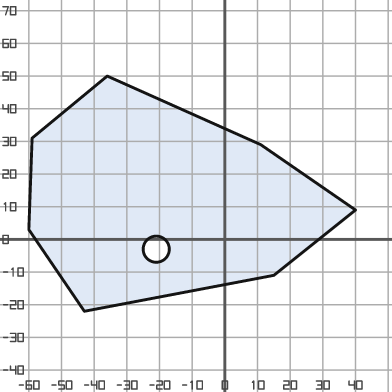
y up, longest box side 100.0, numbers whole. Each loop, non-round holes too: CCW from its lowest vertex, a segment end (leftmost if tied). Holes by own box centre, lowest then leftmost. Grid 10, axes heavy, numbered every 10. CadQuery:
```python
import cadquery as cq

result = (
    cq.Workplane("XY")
    .moveTo(-43.0, -22.0)
    .lineTo(15.0, -11.0)
    .lineTo(40.0, 9.0)
    .lineTo(11.0, 29.0)
    .lineTo(-36.0, 50.0)
    .lineTo(-59.0, 31.0)
    .lineTo(-60.0, 3.0)
    .close()
    .moveTo(-21.0, -3.0)
    .circle(4.0)
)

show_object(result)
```